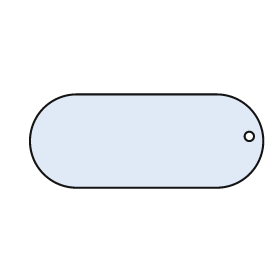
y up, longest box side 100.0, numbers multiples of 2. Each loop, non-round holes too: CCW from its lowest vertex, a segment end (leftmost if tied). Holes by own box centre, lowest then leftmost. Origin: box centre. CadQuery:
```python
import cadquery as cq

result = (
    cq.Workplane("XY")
    .moveTo(-30.0, -20.0)
    .lineTo(30.0, -20.0)
    .threePointArc((50.0, 0.0), (30.0, 20.0))
    .lineTo(-30.0, 20.0)
    .threePointArc((-50.0, 0.0), (-30.0, -20.0))
    .close()
    .moveTo(44.0, 2.0)
    .circle(2.0)
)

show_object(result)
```